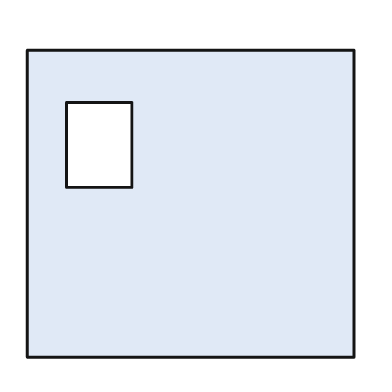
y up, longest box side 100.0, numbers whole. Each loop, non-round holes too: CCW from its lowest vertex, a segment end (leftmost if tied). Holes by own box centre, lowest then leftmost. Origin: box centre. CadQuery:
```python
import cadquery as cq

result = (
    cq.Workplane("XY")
    .moveTo(-50.0, -47.0)
    .lineTo(50.0, -47.0)
    .lineTo(50.0, 47.0)
    .lineTo(-50.0, 47.0)
    .close()
    .moveTo(-38.0, 5.0)
    .lineTo(-18.0, 5.0)
    .lineTo(-18.0, 31.0)
    .lineTo(-38.0, 31.0)
    .close()
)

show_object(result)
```